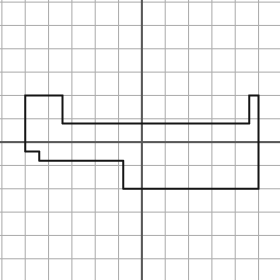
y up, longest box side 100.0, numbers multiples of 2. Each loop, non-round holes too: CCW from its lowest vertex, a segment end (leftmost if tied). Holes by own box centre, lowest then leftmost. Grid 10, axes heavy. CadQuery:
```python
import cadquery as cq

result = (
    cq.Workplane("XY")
    .moveTo(-8.0, -20.0)
    .lineTo(50.0, -20.0)
    .lineTo(50.0, 20.0)
    .lineTo(46.0, 20.0)
    .lineTo(46.0, 8.0)
    .lineTo(-34.0, 8.0)
    .lineTo(-34.0, 20.0)
    .lineTo(-50.0, 20.0)
    .lineTo(-50.0, -4.0)
    .lineTo(-44.0, -4.0)
    .lineTo(-44.0, -8.0)
    .lineTo(-8.0, -8.0)
    .close()
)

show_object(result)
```